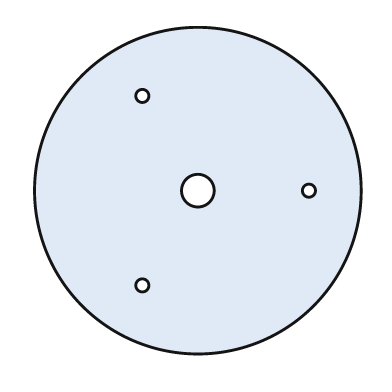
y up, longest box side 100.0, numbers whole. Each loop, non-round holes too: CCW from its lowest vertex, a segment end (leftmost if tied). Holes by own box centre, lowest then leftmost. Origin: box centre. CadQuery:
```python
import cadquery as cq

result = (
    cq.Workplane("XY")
    .moveTo(0.0, 0.0)
    .circle(50.0)
    .moveTo(-17.0, -29.0)
    .circle(2.0)
    .moveTo(0.0, 0.0)
    .circle(5.0)
    .moveTo(34.0, 0.0)
    .circle(2.0)
    .moveTo(-17.0, 29.0)
    .circle(2.0)
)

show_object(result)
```